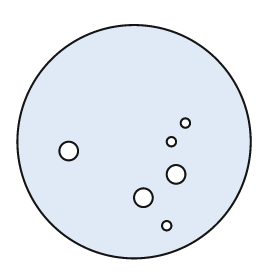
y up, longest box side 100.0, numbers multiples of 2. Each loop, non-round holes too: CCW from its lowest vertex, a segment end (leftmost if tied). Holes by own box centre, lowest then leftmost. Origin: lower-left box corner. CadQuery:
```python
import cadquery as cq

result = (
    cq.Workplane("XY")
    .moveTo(50.0, 50.0)
    .circle(50.0)
    .moveTo(64.0, 14.0)
    .circle(2.0)
    .moveTo(54.0, 26.0)
    .circle(4.0)
    .moveTo(68.0, 36.0)
    .circle(4.0)
    .moveTo(22.0, 46.0)
    .circle(4.0)
    .moveTo(66.0, 50.0)
    .circle(2.0)
    .moveTo(72.0, 58.0)
    .circle(2.0)
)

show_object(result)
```